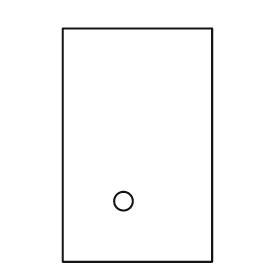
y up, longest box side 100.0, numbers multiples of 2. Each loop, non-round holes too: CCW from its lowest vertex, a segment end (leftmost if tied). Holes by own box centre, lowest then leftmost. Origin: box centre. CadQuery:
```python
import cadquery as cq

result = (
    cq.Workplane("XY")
    .moveTo(-32.0, -50.0)
    .lineTo(32.0, -50.0)
    .lineTo(32.0, 50.0)
    .lineTo(-32.0, 50.0)
    .close()
    .moveTo(-6.0, -24.0)
    .circle(4.0)
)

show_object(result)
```